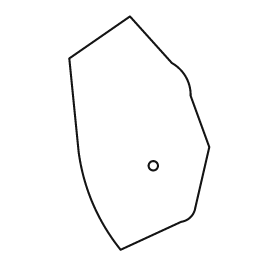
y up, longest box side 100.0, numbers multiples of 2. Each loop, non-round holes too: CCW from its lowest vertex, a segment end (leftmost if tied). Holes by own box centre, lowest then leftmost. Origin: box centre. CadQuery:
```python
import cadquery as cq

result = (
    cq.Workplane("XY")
    .moveTo(-8.0, -50.0)
    .lineTo(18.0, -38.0)
    .threePointArc((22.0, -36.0), (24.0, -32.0))
    .lineTo(30.0, -6.0)
    .lineTo(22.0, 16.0)
    .threePointArc((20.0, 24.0), (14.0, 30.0))
    .lineTo(-4.0, 50.0)
    .lineTo(-30.0, 32.0)
    .lineTo(-26.0, -8.0)
    .threePointArc((-20.0, -30.0), (-8.0, -50.0))
    .close()
    .moveTo(6.0, -14.0)
    .circle(2.0)
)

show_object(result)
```